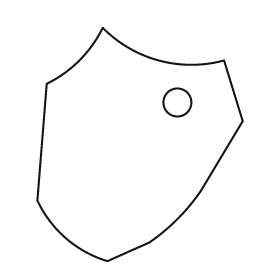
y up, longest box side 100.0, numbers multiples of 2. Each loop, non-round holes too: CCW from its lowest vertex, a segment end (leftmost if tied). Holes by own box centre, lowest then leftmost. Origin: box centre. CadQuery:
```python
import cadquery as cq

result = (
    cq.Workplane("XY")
    .moveTo(-14.0, -50.0)
    .lineTo(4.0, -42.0)
    .threePointArc((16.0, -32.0), (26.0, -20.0))
    .lineTo(44.0, 10.0)
    .lineTo(36.0, 36.0)
    .threePointArc((8.0, 36.0), (-16.0, 50.0))
    .threePointArc((-26.0, 36.0), (-40.0, 26.0))
    .lineTo(-44.0, -24.0)
    .threePointArc((-32.0, -40.0), (-14.0, -50.0))
    .close()
    .moveTo(16.0, 18.0)
    .circle(6.0)
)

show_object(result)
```